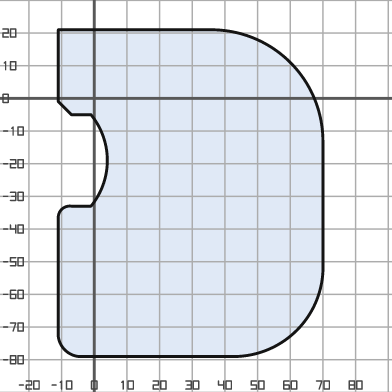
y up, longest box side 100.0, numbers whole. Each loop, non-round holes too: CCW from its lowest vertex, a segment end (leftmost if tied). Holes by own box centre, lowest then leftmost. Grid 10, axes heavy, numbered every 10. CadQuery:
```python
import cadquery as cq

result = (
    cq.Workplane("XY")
    .moveTo(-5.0, -79.0)
    .lineTo(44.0, -79.0)
    .threePointArc((62.0, -71.0), (70.0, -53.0))
    .lineTo(70.0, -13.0)
    .threePointArc((60.0, 11.0), (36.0, 21.0))
    .lineTo(-11.0, 21.0)
    .lineTo(-11.0, -1.0)
    .lineTo(-7.0, -5.0)
    .lineTo(-1.0, -5.0)
    .threePointArc((4.0, -19.0), (-1.0, -33.0))
    .lineTo(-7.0, -33.0)
    .threePointArc((-10.0, -34.0), (-11.0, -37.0))
    .lineTo(-11.0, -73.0)
    .threePointArc((-9.0, -77.0), (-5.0, -79.0))
    .close()
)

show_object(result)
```